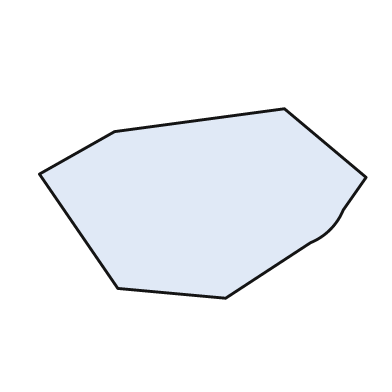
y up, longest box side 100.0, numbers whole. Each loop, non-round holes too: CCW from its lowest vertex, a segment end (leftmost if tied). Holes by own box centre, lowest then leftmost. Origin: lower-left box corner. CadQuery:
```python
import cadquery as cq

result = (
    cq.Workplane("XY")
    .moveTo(57.0, 0.0)
    .lineTo(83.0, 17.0)
    .threePointArc((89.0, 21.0), (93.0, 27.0))
    .lineTo(100.0, 37.0)
    .lineTo(75.0, 58.0)
    .lineTo(23.0, 51.0)
    .lineTo(0.0, 38.0)
    .lineTo(24.0, 3.0)
    .close()
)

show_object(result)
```